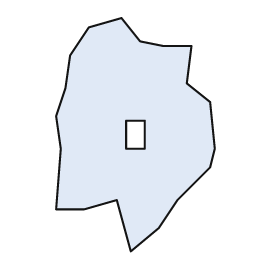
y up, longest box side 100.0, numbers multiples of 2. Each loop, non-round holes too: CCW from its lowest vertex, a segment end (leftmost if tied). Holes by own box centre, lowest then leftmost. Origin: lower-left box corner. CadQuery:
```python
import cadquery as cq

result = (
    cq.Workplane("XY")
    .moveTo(32.0, 0.0)
    .lineTo(44.0, 10.0)
    .lineTo(52.0, 22.0)
    .lineTo(66.0, 36.0)
    .lineTo(68.0, 44.0)
    .lineTo(66.0, 64.0)
    .lineTo(56.0, 72.0)
    .lineTo(58.0, 88.0)
    .lineTo(46.0, 88.0)
    .lineTo(36.0, 90.0)
    .lineTo(28.0, 100.0)
    .lineTo(14.0, 96.0)
    .lineTo(6.0, 84.0)
    .lineTo(4.0, 70.0)
    .lineTo(0.0, 58.0)
    .lineTo(2.0, 44.0)
    .lineTo(0.0, 18.0)
    .lineTo(12.0, 18.0)
    .lineTo(26.0, 22.0)
    .close()
    .moveTo(30.0, 44.0)
    .lineTo(38.0, 44.0)
    .lineTo(38.0, 56.0)
    .lineTo(30.0, 56.0)
    .close()
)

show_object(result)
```